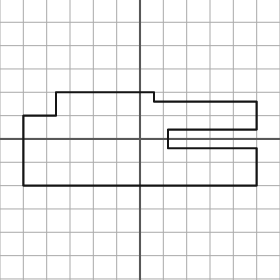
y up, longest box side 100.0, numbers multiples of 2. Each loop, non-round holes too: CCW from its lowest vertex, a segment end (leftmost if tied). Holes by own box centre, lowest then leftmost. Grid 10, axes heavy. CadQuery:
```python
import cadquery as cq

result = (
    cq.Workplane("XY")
    .moveTo(-50.0, -20.0)
    .lineTo(50.0, -20.0)
    .lineTo(50.0, -4.0)
    .lineTo(12.0, -4.0)
    .lineTo(12.0, 4.0)
    .lineTo(50.0, 4.0)
    .lineTo(50.0, 16.0)
    .lineTo(6.0, 16.0)
    .lineTo(6.0, 20.0)
    .lineTo(-36.0, 20.0)
    .lineTo(-36.0, 10.0)
    .lineTo(-50.0, 10.0)
    .close()
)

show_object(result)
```